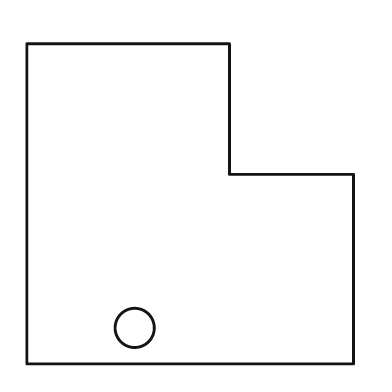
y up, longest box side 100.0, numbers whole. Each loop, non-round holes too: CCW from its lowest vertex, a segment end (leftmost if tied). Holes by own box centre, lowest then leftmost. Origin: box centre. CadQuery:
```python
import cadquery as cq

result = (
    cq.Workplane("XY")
    .moveTo(-50.0, -49.0)
    .lineTo(50.0, -49.0)
    .lineTo(50.0, 9.0)
    .lineTo(12.0, 9.0)
    .lineTo(12.0, 49.0)
    .lineTo(-50.0, 49.0)
    .close()
    .moveTo(-17.0, -38.0)
    .circle(6.0)
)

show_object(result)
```